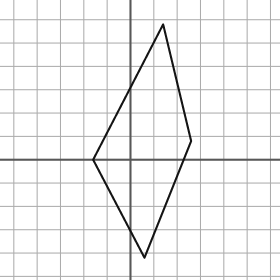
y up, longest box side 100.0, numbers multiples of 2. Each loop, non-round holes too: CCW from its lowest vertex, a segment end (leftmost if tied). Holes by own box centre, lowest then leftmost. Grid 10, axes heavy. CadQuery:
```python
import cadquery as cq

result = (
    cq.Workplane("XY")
    .moveTo(6.0, -42.0)
    .lineTo(26.0, 8.0)
    .lineTo(14.0, 58.0)
    .lineTo(-16.0, 0.0)
    .close()
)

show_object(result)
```